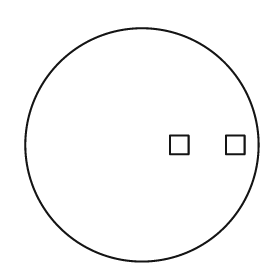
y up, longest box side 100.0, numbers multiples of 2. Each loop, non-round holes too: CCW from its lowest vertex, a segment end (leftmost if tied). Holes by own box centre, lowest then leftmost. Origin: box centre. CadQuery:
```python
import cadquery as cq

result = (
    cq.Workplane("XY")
    .moveTo(0.0, 0.0)
    .circle(50.0)
    .moveTo(12.0, -4.0)
    .lineTo(20.0, -4.0)
    .lineTo(20.0, 4.0)
    .lineTo(12.0, 4.0)
    .close()
    .moveTo(36.0, -4.0)
    .lineTo(44.0, -4.0)
    .lineTo(44.0, 4.0)
    .lineTo(36.0, 4.0)
    .close()
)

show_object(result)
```